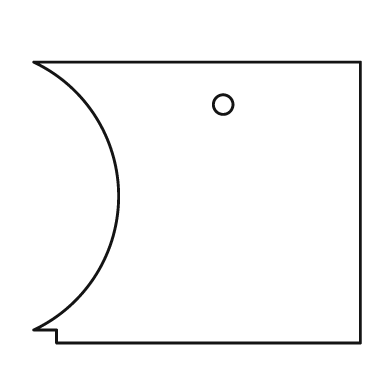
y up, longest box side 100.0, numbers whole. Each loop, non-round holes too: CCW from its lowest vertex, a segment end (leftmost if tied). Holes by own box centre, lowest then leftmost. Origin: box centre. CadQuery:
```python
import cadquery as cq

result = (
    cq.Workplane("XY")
    .moveTo(-43.0, -43.0)
    .lineTo(50.0, -43.0)
    .lineTo(50.0, 43.0)
    .lineTo(-50.0, 43.0)
    .threePointArc((-24.0, 2.0), (-50.0, -39.0))
    .lineTo(-43.0, -39.0)
    .close()
    .moveTo(8.0, 30.0)
    .circle(3.0)
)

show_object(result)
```